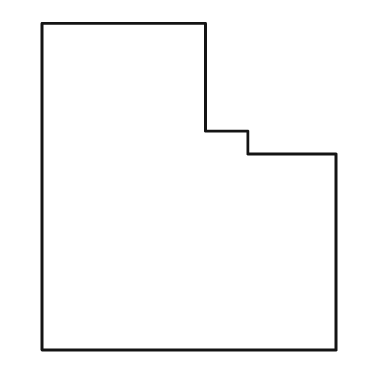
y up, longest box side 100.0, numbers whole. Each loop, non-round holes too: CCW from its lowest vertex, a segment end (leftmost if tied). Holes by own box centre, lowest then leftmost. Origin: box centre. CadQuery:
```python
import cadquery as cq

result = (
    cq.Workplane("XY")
    .moveTo(-45.0, -50.0)
    .lineTo(45.0, -50.0)
    .lineTo(45.0, 10.0)
    .lineTo(18.0, 10.0)
    .lineTo(18.0, 17.0)
    .lineTo(5.0, 17.0)
    .lineTo(5.0, 50.0)
    .lineTo(-45.0, 50.0)
    .close()
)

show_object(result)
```